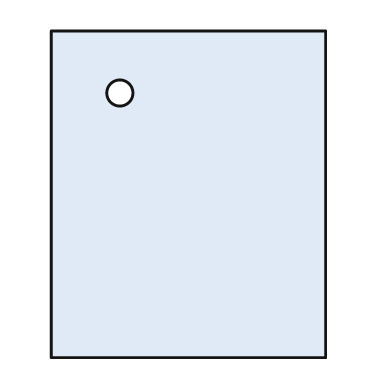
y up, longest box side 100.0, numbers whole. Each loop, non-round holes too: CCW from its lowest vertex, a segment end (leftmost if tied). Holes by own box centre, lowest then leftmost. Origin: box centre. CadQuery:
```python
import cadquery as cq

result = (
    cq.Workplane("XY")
    .moveTo(-42.0, -50.0)
    .lineTo(42.0, -50.0)
    .lineTo(42.0, 50.0)
    .lineTo(-42.0, 50.0)
    .close()
    .moveTo(-21.0, 31.0)
    .circle(4.0)
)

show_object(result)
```